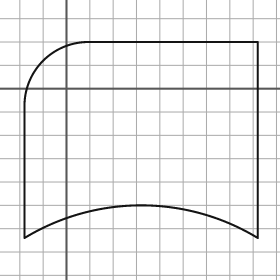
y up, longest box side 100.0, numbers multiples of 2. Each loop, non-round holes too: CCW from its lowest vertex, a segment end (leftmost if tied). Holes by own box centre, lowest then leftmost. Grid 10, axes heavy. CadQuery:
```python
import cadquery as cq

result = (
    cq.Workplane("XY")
    .moveTo(-18.0, -64.0)
    .threePointArc((32.0, -50.0), (82.0, -64.0))
    .lineTo(82.0, 20.0)
    .lineTo(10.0, 20.0)
    .threePointArc((-10.0, 12.0), (-18.0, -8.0))
    .close()
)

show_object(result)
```